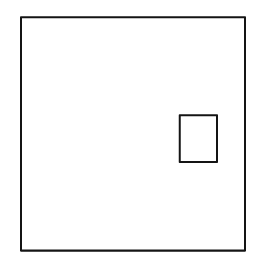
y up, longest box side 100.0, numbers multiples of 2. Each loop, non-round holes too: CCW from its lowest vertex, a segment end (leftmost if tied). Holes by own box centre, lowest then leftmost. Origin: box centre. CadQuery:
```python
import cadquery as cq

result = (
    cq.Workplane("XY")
    .moveTo(-48.0, -50.0)
    .lineTo(48.0, -50.0)
    .lineTo(48.0, 50.0)
    .lineTo(-48.0, 50.0)
    .close()
    .moveTo(20.0, -12.0)
    .lineTo(36.0, -12.0)
    .lineTo(36.0, 8.0)
    .lineTo(20.0, 8.0)
    .close()
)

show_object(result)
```